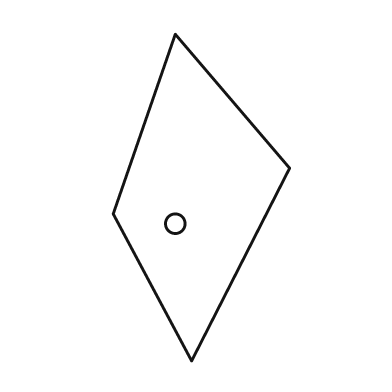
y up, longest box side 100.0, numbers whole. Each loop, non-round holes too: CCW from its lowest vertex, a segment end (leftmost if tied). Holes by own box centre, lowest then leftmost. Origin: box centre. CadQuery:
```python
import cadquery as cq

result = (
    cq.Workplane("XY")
    .moveTo(-3.0, -50.0)
    .lineTo(27.0, 9.0)
    .lineTo(-8.0, 50.0)
    .lineTo(-27.0, -5.0)
    .close()
    .moveTo(-8.0, -8.0)
    .circle(3.0)
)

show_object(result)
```